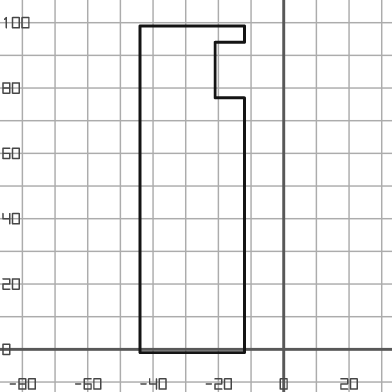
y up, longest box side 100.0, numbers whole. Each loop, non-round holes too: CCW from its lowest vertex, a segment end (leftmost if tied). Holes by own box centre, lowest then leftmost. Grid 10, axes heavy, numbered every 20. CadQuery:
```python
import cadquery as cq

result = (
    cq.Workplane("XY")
    .moveTo(-44.0, -1.0)
    .lineTo(-12.0, -1.0)
    .lineTo(-12.0, 77.0)
    .lineTo(-21.0, 77.0)
    .lineTo(-21.0, 94.0)
    .lineTo(-12.0, 94.0)
    .lineTo(-12.0, 99.0)
    .lineTo(-44.0, 99.0)
    .close()
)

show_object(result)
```